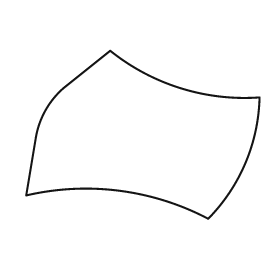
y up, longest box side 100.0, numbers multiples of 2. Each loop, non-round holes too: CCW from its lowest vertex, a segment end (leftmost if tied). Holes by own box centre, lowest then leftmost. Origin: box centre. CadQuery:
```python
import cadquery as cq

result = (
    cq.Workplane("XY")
    .moveTo(28.0, -36.0)
    .threePointArc((44.0, -12.0), (50.0, 16.0))
    .threePointArc((16.0, 20.0), (-14.0, 36.0))
    .lineTo(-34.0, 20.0)
    .threePointArc((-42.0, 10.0), (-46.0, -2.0))
    .lineTo(-50.0, -26.0)
    .threePointArc((-10.0, -24.0), (28.0, -36.0))
    .close()
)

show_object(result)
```